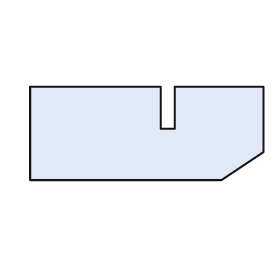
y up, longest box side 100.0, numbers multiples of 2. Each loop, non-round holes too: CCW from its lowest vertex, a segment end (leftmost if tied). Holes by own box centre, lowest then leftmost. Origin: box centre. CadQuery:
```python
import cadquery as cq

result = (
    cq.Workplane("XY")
    .moveTo(-50.0, -20.0)
    .lineTo(32.0, -20.0)
    .lineTo(50.0, -8.0)
    .lineTo(50.0, 20.0)
    .lineTo(12.0, 20.0)
    .lineTo(12.0, 2.0)
    .lineTo(6.0, 2.0)
    .lineTo(6.0, 20.0)
    .lineTo(-50.0, 20.0)
    .close()
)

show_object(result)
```